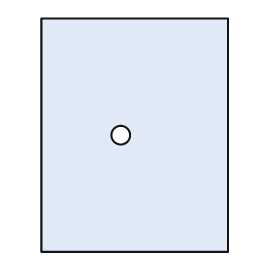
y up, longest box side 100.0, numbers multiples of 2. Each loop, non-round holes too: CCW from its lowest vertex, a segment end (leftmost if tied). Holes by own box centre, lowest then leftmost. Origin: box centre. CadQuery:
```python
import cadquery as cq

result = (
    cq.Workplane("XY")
    .moveTo(-40.0, -50.0)
    .lineTo(40.0, -50.0)
    .lineTo(40.0, 50.0)
    .lineTo(-40.0, 50.0)
    .close()
    .moveTo(-6.0, 0.0)
    .circle(4.0)
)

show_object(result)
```